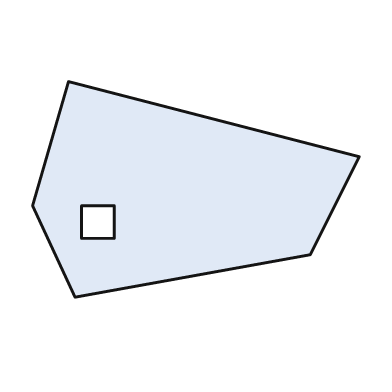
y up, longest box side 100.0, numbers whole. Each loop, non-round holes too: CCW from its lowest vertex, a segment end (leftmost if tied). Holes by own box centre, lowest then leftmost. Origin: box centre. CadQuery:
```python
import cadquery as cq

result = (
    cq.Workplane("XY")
    .moveTo(-37.0, -33.0)
    .lineTo(35.0, -20.0)
    .lineTo(50.0, 10.0)
    .lineTo(-39.0, 33.0)
    .lineTo(-50.0, -5.0)
    .close()
    .moveTo(-35.0, -15.0)
    .lineTo(-25.0, -15.0)
    .lineTo(-25.0, -5.0)
    .lineTo(-35.0, -5.0)
    .close()
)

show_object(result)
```